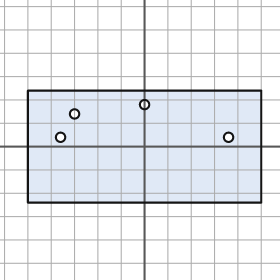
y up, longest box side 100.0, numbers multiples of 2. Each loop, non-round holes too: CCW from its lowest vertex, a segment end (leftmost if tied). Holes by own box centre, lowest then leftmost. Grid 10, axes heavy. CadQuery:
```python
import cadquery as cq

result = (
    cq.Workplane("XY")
    .moveTo(-50.0, -24.0)
    .lineTo(50.0, -24.0)
    .lineTo(50.0, 24.0)
    .lineTo(-50.0, 24.0)
    .close()
    .moveTo(-36.0, 4.0)
    .circle(2.0)
    .moveTo(36.0, 4.0)
    .circle(2.0)
    .moveTo(-30.0, 14.0)
    .circle(2.0)
    .moveTo(0.0, 18.0)
    .circle(2.0)
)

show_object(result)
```